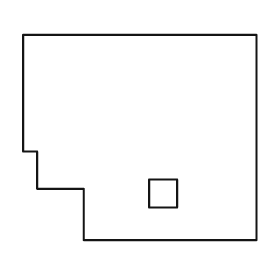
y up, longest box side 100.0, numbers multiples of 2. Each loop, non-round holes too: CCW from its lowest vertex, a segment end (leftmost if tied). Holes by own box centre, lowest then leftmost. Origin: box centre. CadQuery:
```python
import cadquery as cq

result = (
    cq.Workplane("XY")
    .moveTo(-24.0, -44.0)
    .lineTo(50.0, -44.0)
    .lineTo(50.0, 44.0)
    .lineTo(-50.0, 44.0)
    .lineTo(-50.0, -6.0)
    .lineTo(-44.0, -6.0)
    .lineTo(-44.0, -22.0)
    .lineTo(-24.0, -22.0)
    .close()
    .moveTo(4.0, -30.0)
    .lineTo(16.0, -30.0)
    .lineTo(16.0, -18.0)
    .lineTo(4.0, -18.0)
    .close()
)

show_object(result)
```